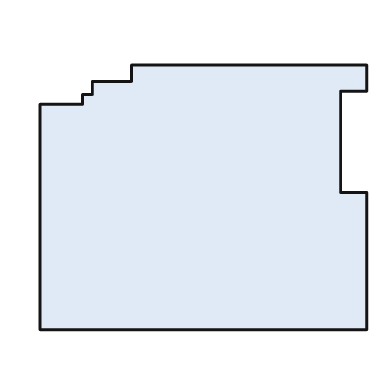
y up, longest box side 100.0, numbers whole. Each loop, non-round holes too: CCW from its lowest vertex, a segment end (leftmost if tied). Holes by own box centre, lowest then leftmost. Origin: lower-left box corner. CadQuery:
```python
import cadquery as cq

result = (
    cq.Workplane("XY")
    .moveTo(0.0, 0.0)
    .lineTo(100.0, 0.0)
    .lineTo(100.0, 42.0)
    .lineTo(92.0, 42.0)
    .lineTo(92.0, 73.0)
    .lineTo(100.0, 73.0)
    .lineTo(100.0, 81.0)
    .lineTo(28.0, 81.0)
    .lineTo(28.0, 76.0)
    .lineTo(16.0, 76.0)
    .lineTo(16.0, 72.0)
    .lineTo(13.0, 72.0)
    .lineTo(13.0, 69.0)
    .lineTo(0.0, 69.0)
    .close()
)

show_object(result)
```